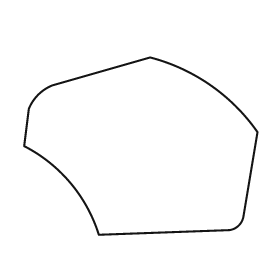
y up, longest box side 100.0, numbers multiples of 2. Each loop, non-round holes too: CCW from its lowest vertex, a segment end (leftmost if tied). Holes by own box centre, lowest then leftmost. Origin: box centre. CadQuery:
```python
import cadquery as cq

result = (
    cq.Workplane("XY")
    .moveTo(-18.0, -38.0)
    .lineTo(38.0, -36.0)
    .threePointArc((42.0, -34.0), (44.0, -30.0))
    .lineTo(50.0, 6.0)
    .threePointArc((30.0, 26.0), (4.0, 38.0))
    .lineTo(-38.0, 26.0)
    .threePointArc((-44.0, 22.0), (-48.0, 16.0))
    .lineTo(-50.0, 0.0)
    .threePointArc((-30.0, -16.0), (-18.0, -38.0))
    .close()
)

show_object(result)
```